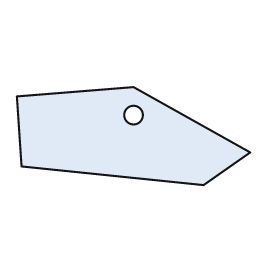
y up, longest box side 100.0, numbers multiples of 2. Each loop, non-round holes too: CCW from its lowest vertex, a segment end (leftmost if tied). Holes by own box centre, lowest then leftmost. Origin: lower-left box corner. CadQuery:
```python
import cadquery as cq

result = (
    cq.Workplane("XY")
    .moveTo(80.0, 0.0)
    .lineTo(100.0, 14.0)
    .lineTo(50.0, 42.0)
    .lineTo(0.0, 38.0)
    .lineTo(2.0, 8.0)
    .close()
    .moveTo(50.0, 30.0)
    .circle(4.0)
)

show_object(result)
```